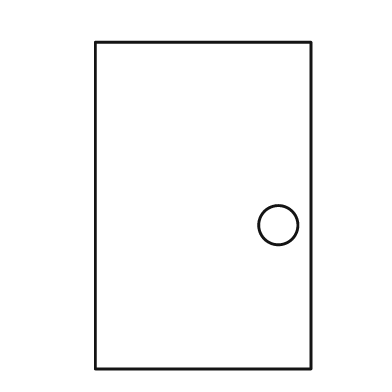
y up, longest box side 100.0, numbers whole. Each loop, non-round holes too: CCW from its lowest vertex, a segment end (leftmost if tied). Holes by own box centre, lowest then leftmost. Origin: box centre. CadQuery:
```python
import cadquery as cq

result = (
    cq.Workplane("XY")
    .moveTo(-33.0, -50.0)
    .lineTo(33.0, -50.0)
    .lineTo(33.0, 50.0)
    .lineTo(-33.0, 50.0)
    .close()
    .moveTo(23.0, -6.0)
    .circle(6.0)
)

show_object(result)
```